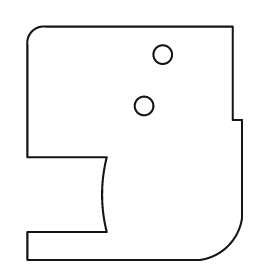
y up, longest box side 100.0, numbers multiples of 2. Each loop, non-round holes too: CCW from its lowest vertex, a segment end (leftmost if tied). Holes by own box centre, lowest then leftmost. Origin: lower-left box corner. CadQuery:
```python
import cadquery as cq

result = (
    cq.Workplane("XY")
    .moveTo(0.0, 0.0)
    .lineTo(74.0, 0.0)
    .threePointArc((86.0, 6.0), (92.0, 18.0))
    .lineTo(92.0, 60.0)
    .lineTo(88.0, 60.0)
    .lineTo(88.0, 100.0)
    .lineTo(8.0, 100.0)
    .threePointArc((2.0, 98.0), (0.0, 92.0))
    .lineTo(0.0, 44.0)
    .lineTo(34.0, 44.0)
    .threePointArc((32.0, 28.0), (34.0, 12.0))
    .lineTo(0.0, 12.0)
    .close()
    .moveTo(50.0, 66.0)
    .circle(4.0)
    .moveTo(58.0, 88.0)
    .circle(4.0)
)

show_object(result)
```